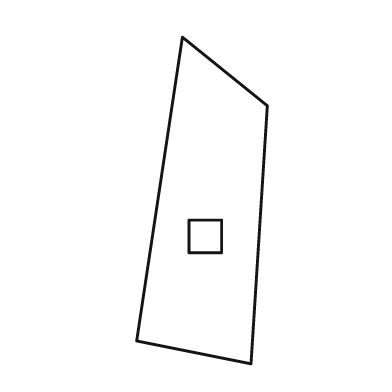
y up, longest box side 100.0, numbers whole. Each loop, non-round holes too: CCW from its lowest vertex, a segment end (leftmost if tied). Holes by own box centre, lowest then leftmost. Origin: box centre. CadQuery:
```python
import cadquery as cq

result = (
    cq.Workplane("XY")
    .moveTo(15.0, -50.0)
    .lineTo(20.0, 29.0)
    .lineTo(-6.0, 50.0)
    .lineTo(-20.0, -43.0)
    .close()
    .moveTo(-4.0, -16.0)
    .lineTo(6.0, -16.0)
    .lineTo(6.0, -6.0)
    .lineTo(-4.0, -6.0)
    .close()
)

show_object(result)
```